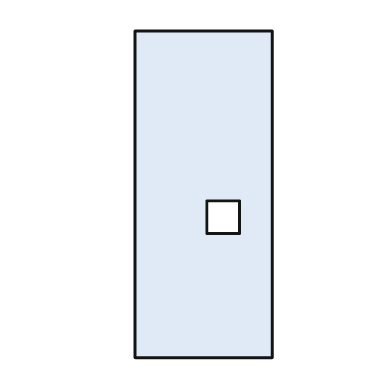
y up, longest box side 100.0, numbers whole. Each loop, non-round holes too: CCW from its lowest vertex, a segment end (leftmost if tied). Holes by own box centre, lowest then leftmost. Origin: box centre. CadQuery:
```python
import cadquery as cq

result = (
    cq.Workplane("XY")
    .moveTo(-21.0, -50.0)
    .lineTo(21.0, -50.0)
    .lineTo(21.0, 50.0)
    .lineTo(-21.0, 50.0)
    .close()
    .moveTo(1.0, -12.0)
    .lineTo(11.0, -12.0)
    .lineTo(11.0, -2.0)
    .lineTo(1.0, -2.0)
    .close()
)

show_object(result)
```